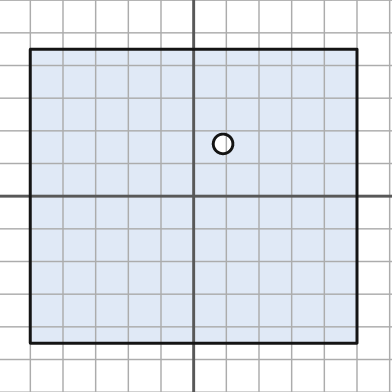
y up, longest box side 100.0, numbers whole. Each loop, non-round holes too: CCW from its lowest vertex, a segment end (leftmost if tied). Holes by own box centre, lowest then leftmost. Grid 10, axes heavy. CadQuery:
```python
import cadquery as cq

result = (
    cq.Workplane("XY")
    .moveTo(-50.0, -45.0)
    .lineTo(50.0, -45.0)
    .lineTo(50.0, 45.0)
    .lineTo(-50.0, 45.0)
    .close()
    .moveTo(9.0, 16.0)
    .circle(3.0)
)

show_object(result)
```